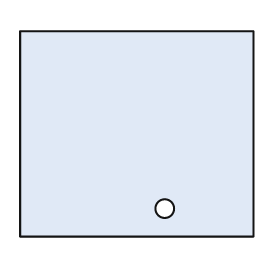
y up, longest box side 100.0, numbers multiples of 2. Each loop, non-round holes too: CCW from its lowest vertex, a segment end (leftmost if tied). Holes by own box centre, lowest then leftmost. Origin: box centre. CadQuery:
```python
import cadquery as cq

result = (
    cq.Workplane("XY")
    .moveTo(-50.0, -44.0)
    .lineTo(50.0, -44.0)
    .lineTo(50.0, 44.0)
    .lineTo(-50.0, 44.0)
    .close()
    .moveTo(12.0, -32.0)
    .circle(4.0)
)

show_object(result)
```